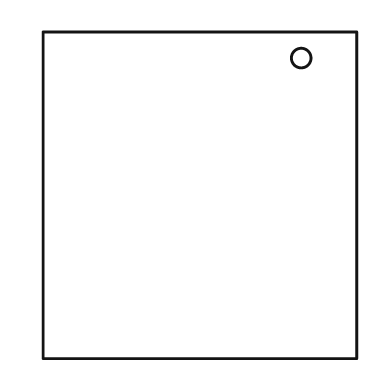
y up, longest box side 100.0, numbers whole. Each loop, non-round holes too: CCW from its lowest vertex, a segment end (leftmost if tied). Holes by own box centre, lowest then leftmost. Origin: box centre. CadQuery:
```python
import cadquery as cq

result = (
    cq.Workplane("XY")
    .moveTo(-48.0, -50.0)
    .lineTo(48.0, -50.0)
    .lineTo(48.0, 50.0)
    .lineTo(-48.0, 50.0)
    .close()
    .moveTo(31.0, 42.0)
    .circle(3.0)
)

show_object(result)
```